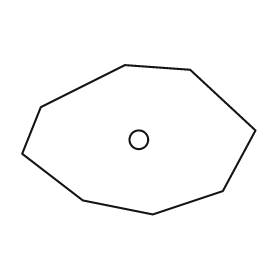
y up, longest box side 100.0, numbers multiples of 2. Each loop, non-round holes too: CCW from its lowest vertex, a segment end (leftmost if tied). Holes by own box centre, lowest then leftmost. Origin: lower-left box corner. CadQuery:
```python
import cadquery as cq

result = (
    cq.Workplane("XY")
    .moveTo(56.0, 0.0)
    .lineTo(86.0, 10.0)
    .lineTo(100.0, 36.0)
    .lineTo(72.0, 62.0)
    .lineTo(44.0, 64.0)
    .lineTo(8.0, 46.0)
    .lineTo(0.0, 26.0)
    .lineTo(26.0, 6.0)
    .close()
    .moveTo(50.0, 32.0)
    .circle(4.0)
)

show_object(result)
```